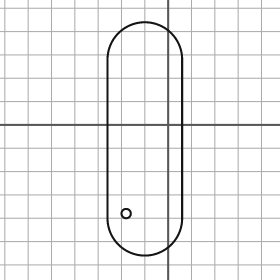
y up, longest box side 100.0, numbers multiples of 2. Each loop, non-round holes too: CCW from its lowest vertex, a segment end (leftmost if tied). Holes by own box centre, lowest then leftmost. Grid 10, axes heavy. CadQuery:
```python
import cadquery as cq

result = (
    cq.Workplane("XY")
    .moveTo(-26.0, -40.0)
    .threePointArc((-10.0, -56.0), (6.0, -40.0))
    .lineTo(6.0, 28.0)
    .threePointArc((-10.0, 44.0), (-26.0, 28.0))
    .close()
    .moveTo(-18.0, -38.0)
    .circle(2.0)
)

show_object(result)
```